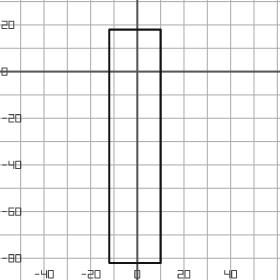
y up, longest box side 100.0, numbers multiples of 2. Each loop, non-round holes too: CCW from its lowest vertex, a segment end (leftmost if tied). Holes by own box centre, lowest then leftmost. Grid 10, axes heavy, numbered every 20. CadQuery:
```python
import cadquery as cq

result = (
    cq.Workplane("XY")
    .moveTo(-12.0, -82.0)
    .lineTo(10.0, -82.0)
    .lineTo(10.0, 18.0)
    .lineTo(-12.0, 18.0)
    .close()
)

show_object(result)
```